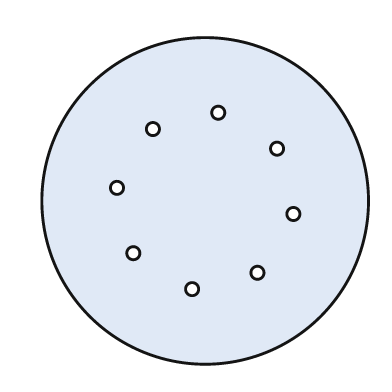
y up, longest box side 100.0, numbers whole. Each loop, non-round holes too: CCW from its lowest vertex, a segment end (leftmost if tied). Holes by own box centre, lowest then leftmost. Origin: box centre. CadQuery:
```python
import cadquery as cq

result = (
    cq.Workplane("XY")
    .moveTo(0.0, 0.0)
    .circle(50.0)
    .moveTo(-4.0, -27.0)
    .circle(2.0)
    .moveTo(16.0, -22.0)
    .circle(2.0)
    .moveTo(-22.0, -16.0)
    .circle(2.0)
    .moveTo(27.0, -4.0)
    .circle(2.0)
    .moveTo(-27.0, 4.0)
    .circle(2.0)
    .moveTo(22.0, 16.0)
    .circle(2.0)
    .moveTo(-16.0, 22.0)
    .circle(2.0)
    .moveTo(4.0, 27.0)
    .circle(2.0)
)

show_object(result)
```